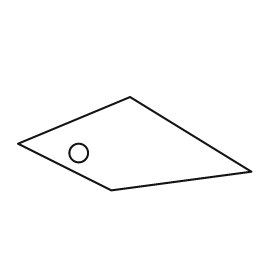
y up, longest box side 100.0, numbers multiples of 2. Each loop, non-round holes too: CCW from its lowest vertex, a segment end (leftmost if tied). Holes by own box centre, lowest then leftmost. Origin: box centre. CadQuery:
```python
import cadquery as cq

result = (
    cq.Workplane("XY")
    .moveTo(-10.0, -20.0)
    .lineTo(50.0, -12.0)
    .lineTo(-2.0, 20.0)
    .lineTo(-50.0, 0.0)
    .close()
    .moveTo(-24.0, -4.0)
    .circle(4.0)
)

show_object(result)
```